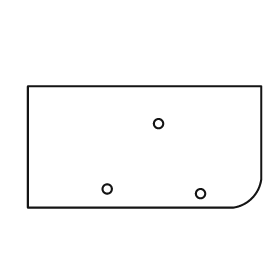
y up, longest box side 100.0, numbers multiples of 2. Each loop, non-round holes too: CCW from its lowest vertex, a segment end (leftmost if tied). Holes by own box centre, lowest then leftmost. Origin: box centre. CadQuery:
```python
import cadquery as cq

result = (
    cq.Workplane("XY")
    .moveTo(-50.0, -26.0)
    .lineTo(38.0, -26.0)
    .threePointArc((46.0, -22.0), (50.0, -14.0))
    .lineTo(50.0, 26.0)
    .lineTo(-50.0, 26.0)
    .close()
    .moveTo(24.0, -20.0)
    .circle(2.0)
    .moveTo(-16.0, -18.0)
    .circle(2.0)
    .moveTo(6.0, 10.0)
    .circle(2.0)
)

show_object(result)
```